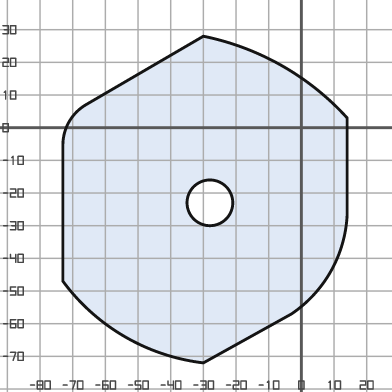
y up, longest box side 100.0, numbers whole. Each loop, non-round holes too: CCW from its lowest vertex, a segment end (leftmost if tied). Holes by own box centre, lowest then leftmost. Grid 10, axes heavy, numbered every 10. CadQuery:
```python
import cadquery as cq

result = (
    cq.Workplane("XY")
    .moveTo(-30.0, -72.0)
    .lineTo(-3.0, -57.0)
    .threePointArc((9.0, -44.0), (14.0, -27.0))
    .lineTo(14.0, 3.0)
    .threePointArc((-6.0, 19.0), (-30.0, 28.0))
    .lineTo(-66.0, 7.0)
    .threePointArc((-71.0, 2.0), (-73.0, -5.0))
    .lineTo(-73.0, -47.0)
    .threePointArc((-54.0, -64.0), (-30.0, -72.0))
    .close()
    .moveTo(-28.0, -23.0)
    .circle(7.0)
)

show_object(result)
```